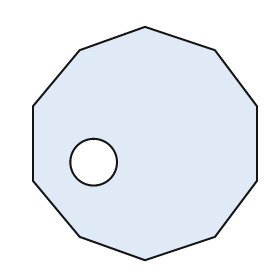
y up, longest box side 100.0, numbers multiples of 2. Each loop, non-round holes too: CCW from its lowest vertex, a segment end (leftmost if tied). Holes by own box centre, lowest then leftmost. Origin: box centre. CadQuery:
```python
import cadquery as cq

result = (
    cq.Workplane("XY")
    .moveTo(0.0, -50.0)
    .lineTo(30.0, -40.0)
    .lineTo(48.0, -16.0)
    .lineTo(48.0, 16.0)
    .lineTo(30.0, 40.0)
    .lineTo(0.0, 50.0)
    .lineTo(-28.0, 40.0)
    .lineTo(-48.0, 16.0)
    .lineTo(-48.0, -16.0)
    .lineTo(-28.0, -40.0)
    .close()
    .moveTo(-22.0, -8.0)
    .circle(10.0)
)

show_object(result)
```